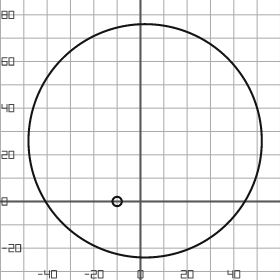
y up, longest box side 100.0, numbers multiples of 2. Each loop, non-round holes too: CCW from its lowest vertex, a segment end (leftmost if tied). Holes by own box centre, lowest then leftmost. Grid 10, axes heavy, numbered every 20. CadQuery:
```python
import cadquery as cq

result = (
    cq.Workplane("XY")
    .moveTo(2.0, 26.0)
    .circle(50.0)
    .moveTo(-10.0, 0.0)
    .circle(2.0)
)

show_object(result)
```